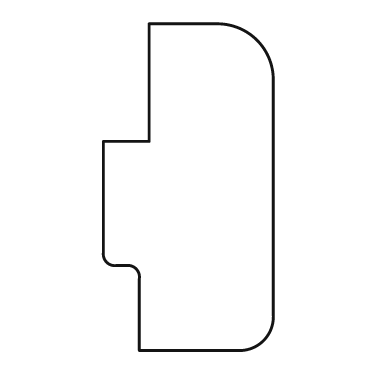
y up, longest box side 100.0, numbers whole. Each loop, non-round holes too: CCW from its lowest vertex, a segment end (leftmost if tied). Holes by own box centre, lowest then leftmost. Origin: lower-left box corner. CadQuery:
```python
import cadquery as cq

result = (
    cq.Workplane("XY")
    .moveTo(11.0, 0.0)
    .lineTo(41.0, 0.0)
    .threePointArc((49.0, 3.0), (52.0, 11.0))
    .lineTo(52.0, 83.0)
    .threePointArc((47.0, 95.0), (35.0, 100.0))
    .lineTo(14.0, 100.0)
    .lineTo(14.0, 64.0)
    .lineTo(0.0, 64.0)
    .lineTo(0.0, 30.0)
    .threePointArc((1.0, 27.0), (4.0, 26.0))
    .lineTo(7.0, 26.0)
    .threePointArc((10.0, 25.0), (11.0, 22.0))
    .close()
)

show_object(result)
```